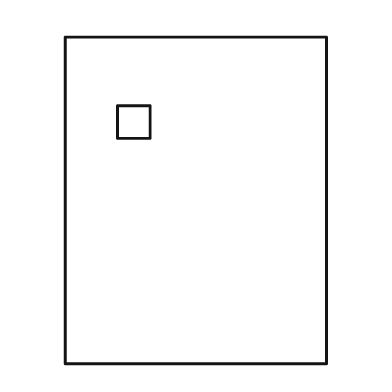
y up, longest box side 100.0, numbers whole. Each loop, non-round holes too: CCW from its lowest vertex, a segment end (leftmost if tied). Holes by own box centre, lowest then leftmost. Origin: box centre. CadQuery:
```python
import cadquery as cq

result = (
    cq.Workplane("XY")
    .moveTo(-40.0, -50.0)
    .lineTo(40.0, -50.0)
    .lineTo(40.0, 50.0)
    .lineTo(-40.0, 50.0)
    .close()
    .moveTo(-24.0, 19.0)
    .lineTo(-14.0, 19.0)
    .lineTo(-14.0, 29.0)
    .lineTo(-24.0, 29.0)
    .close()
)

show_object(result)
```